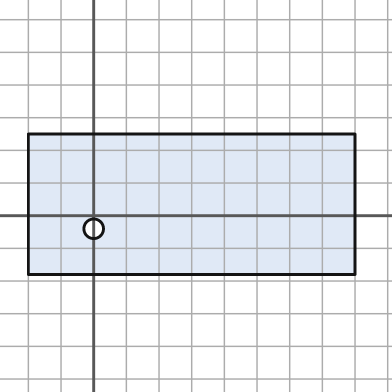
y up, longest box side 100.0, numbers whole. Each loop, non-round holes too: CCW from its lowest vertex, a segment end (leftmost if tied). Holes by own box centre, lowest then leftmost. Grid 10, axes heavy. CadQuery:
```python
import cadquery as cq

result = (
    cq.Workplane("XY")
    .moveTo(-20.0, -18.0)
    .lineTo(80.0, -18.0)
    .lineTo(80.0, 25.0)
    .lineTo(-20.0, 25.0)
    .close()
    .moveTo(0.0, -4.0)
    .circle(3.0)
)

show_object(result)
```